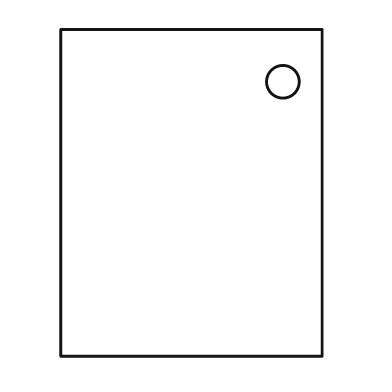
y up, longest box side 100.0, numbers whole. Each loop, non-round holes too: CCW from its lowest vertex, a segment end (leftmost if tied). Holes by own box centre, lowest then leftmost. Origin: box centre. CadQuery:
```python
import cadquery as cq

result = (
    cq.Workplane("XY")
    .moveTo(-40.0, -50.0)
    .lineTo(40.0, -50.0)
    .lineTo(40.0, 50.0)
    .lineTo(-40.0, 50.0)
    .close()
    .moveTo(28.0, 34.0)
    .circle(5.0)
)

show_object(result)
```